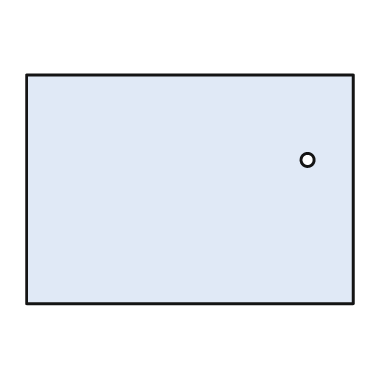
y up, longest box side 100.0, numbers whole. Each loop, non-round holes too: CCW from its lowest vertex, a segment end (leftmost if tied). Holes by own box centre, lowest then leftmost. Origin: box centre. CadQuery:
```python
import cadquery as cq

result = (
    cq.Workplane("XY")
    .moveTo(-50.0, -35.0)
    .lineTo(50.0, -35.0)
    .lineTo(50.0, 35.0)
    .lineTo(-50.0, 35.0)
    .close()
    .moveTo(36.0, 9.0)
    .circle(2.0)
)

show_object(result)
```